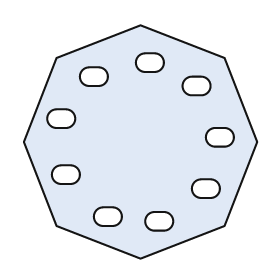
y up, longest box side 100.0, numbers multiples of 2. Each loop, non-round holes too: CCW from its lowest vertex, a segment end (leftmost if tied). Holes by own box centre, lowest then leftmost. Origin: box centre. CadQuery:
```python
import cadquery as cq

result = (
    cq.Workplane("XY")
    .moveTo(0.0, -50.0)
    .lineTo(36.0, -36.0)
    .lineTo(50.0, 0.0)
    .lineTo(36.0, 36.0)
    .lineTo(0.0, 50.0)
    .lineTo(-36.0, 36.0)
    .lineTo(-50.0, 0.0)
    .lineTo(-36.0, -36.0)
    .close()
    .moveTo(6.0, -38.0)
    .lineTo(10.0, -38.0)
    .threePointArc((14.0, -34.0), (10.0, -30.0))
    .lineTo(6.0, -30.0)
    .threePointArc((2.0, -34.0), (6.0, -38.0))
    .close()
    .moveTo(-16.0, -36.0)
    .lineTo(-12.0, -36.0)
    .threePointArc((-8.0, -32.0), (-12.0, -28.0))
    .lineTo(-16.0, -28.0)
    .threePointArc((-20.0, -32.0), (-16.0, -36.0))
    .close()
    .moveTo(26.0, -24.0)
    .lineTo(30.0, -24.0)
    .threePointArc((34.0, -20.0), (30.0, -16.0))
    .lineTo(26.0, -16.0)
    .threePointArc((22.0, -20.0), (26.0, -24.0))
    .close()
    .moveTo(-34.0, -18.0)
    .lineTo(-30.0, -18.0)
    .threePointArc((-26.0, -14.0), (-30.0, -10.0))
    .lineTo(-34.0, -10.0)
    .threePointArc((-38.0, -14.0), (-34.0, -18.0))
    .close()
    .moveTo(32.0, -2.0)
    .lineTo(36.0, -2.0)
    .threePointArc((40.0, 2.0), (36.0, 6.0))
    .lineTo(32.0, 6.0)
    .threePointArc((28.0, 2.0), (32.0, -2.0))
    .close()
    .moveTo(-36.0, 6.0)
    .lineTo(-32.0, 6.0)
    .threePointArc((-28.0, 10.0), (-32.0, 14.0))
    .lineTo(-36.0, 14.0)
    .threePointArc((-40.0, 10.0), (-36.0, 6.0))
    .close()
    .moveTo(22.0, 20.0)
    .lineTo(26.0, 20.0)
    .threePointArc((30.0, 24.0), (26.0, 28.0))
    .lineTo(22.0, 28.0)
    .threePointArc((18.0, 24.0), (22.0, 20.0))
    .close()
    .moveTo(-22.0, 24.0)
    .lineTo(-18.0, 24.0)
    .threePointArc((-14.0, 28.0), (-18.0, 32.0))
    .lineTo(-22.0, 32.0)
    .threePointArc((-26.0, 28.0), (-22.0, 24.0))
    .close()
    .moveTo(2.0, 30.0)
    .lineTo(6.0, 30.0)
    .threePointArc((10.0, 34.0), (6.0, 38.0))
    .lineTo(2.0, 38.0)
    .threePointArc((-2.0, 34.0), (2.0, 30.0))
    .close()
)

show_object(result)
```